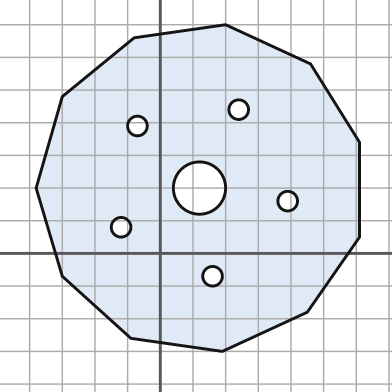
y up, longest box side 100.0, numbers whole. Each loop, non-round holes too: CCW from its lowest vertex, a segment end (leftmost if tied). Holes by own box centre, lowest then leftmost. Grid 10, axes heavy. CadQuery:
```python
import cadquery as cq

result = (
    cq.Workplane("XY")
    .moveTo(19.0, -30.0)
    .lineTo(45.0, -18.0)
    .lineTo(61.0, 5.0)
    .lineTo(61.0, 34.0)
    .lineTo(46.0, 58.0)
    .lineTo(20.0, 70.0)
    .lineTo(-8.0, 66.0)
    .lineTo(-30.0, 48.0)
    .lineTo(-38.0, 20.0)
    .lineTo(-30.0, -7.0)
    .lineTo(-9.0, -26.0)
    .close()
    .moveTo(16.0, -7.0)
    .circle(3.0)
    .moveTo(-12.0, 8.0)
    .circle(3.0)
    .moveTo(39.0, 16.0)
    .circle(3.0)
    .moveTo(12.0, 20.0)
    .circle(8.0)
    .moveTo(-7.0, 39.0)
    .circle(3.0)
    .moveTo(24.0, 44.0)
    .circle(3.0)
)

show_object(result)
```